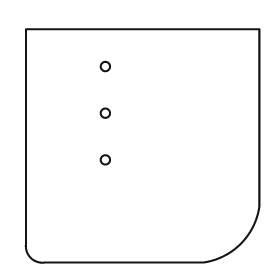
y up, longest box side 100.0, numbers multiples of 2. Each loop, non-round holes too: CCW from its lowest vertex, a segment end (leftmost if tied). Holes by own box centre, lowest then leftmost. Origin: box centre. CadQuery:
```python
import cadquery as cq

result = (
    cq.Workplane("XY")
    .moveTo(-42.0, -50.0)
    .lineTo(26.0, -50.0)
    .threePointArc((42.0, -42.0), (50.0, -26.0))
    .lineTo(50.0, 50.0)
    .lineTo(-50.0, 50.0)
    .lineTo(-50.0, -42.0)
    .threePointArc((-48.0, -48.0), (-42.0, -50.0))
    .close()
    .moveTo(-16.0, -6.0)
    .circle(2.0)
    .moveTo(-16.0, 14.0)
    .circle(2.0)
    .moveTo(-16.0, 34.0)
    .circle(2.0)
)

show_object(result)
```